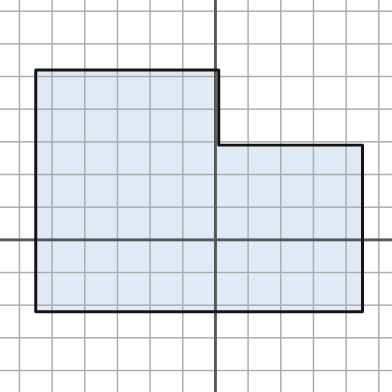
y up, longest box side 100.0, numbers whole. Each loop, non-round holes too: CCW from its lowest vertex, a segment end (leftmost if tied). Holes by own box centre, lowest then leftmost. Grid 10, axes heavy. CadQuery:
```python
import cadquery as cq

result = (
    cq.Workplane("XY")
    .moveTo(-55.0, -22.0)
    .lineTo(45.0, -22.0)
    .lineTo(45.0, 29.0)
    .lineTo(1.0, 29.0)
    .lineTo(1.0, 52.0)
    .lineTo(-55.0, 52.0)
    .close()
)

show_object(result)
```